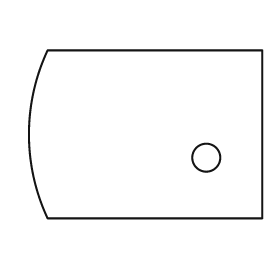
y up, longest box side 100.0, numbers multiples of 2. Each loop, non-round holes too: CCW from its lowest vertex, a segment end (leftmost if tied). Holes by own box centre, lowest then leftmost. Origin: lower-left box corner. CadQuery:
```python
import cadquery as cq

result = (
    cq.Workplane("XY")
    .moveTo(8.0, 0.0)
    .lineTo(100.0, 0.0)
    .lineTo(100.0, 72.0)
    .lineTo(8.0, 72.0)
    .threePointArc((0.0, 36.0), (8.0, 0.0))
    .close()
    .moveTo(76.0, 26.0)
    .circle(6.0)
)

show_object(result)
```